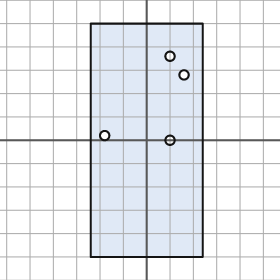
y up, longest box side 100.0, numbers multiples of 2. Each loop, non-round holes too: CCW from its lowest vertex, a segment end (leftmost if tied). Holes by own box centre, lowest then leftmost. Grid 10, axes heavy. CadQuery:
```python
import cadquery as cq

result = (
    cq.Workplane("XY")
    .moveTo(-24.0, -50.0)
    .lineTo(24.0, -50.0)
    .lineTo(24.0, 50.0)
    .lineTo(-24.0, 50.0)
    .close()
    .moveTo(10.0, 0.0)
    .circle(2.0)
    .moveTo(-18.0, 2.0)
    .circle(2.0)
    .moveTo(16.0, 28.0)
    .circle(2.0)
    .moveTo(10.0, 36.0)
    .circle(2.0)
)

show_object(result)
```